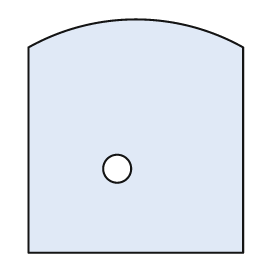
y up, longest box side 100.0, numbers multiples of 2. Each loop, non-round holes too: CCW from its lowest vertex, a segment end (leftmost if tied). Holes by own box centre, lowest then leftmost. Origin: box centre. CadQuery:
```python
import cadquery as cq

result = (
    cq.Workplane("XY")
    .moveTo(-46.0, -50.0)
    .lineTo(46.0, -50.0)
    .lineTo(46.0, 38.0)
    .threePointArc((0.0, 50.0), (-46.0, 38.0))
    .close()
    .moveTo(-8.0, -14.0)
    .circle(6.0)
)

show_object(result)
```